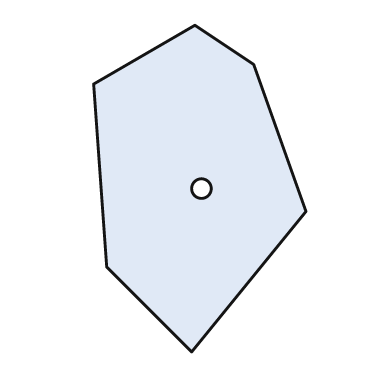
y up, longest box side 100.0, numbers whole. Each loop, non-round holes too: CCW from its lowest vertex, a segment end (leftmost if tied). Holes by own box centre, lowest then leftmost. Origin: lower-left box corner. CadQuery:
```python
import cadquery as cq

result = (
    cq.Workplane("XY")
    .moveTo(30.0, 0.0)
    .lineTo(65.0, 43.0)
    .lineTo(49.0, 88.0)
    .lineTo(31.0, 100.0)
    .lineTo(0.0, 82.0)
    .lineTo(4.0, 26.0)
    .close()
    .moveTo(33.0, 50.0)
    .circle(3.0)
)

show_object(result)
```